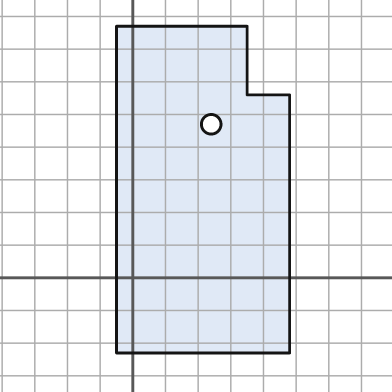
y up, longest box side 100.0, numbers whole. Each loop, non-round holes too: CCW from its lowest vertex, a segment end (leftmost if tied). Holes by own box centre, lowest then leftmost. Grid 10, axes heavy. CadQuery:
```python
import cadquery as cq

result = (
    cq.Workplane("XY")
    .moveTo(-5.0, -23.0)
    .lineTo(48.0, -23.0)
    .lineTo(48.0, 56.0)
    .lineTo(35.0, 56.0)
    .lineTo(35.0, 77.0)
    .lineTo(-5.0, 77.0)
    .close()
    .moveTo(24.0, 47.0)
    .circle(3.0)
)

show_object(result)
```